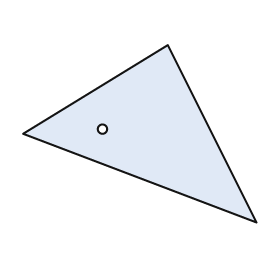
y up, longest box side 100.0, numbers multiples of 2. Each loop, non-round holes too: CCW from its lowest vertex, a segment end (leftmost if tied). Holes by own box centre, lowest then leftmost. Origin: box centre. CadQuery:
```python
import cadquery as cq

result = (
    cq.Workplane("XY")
    .moveTo(50.0, -38.0)
    .lineTo(12.0, 38.0)
    .lineTo(-50.0, 0.0)
    .close()
    .moveTo(-16.0, 2.0)
    .circle(2.0)
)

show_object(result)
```